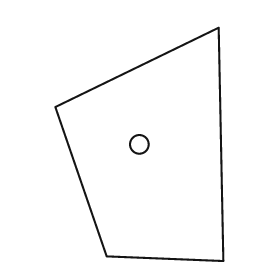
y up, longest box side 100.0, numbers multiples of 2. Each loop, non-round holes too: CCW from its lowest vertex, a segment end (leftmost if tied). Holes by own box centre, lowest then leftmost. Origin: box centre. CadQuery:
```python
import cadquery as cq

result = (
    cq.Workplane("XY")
    .moveTo(36.0, -50.0)
    .lineTo(34.0, 50.0)
    .lineTo(-36.0, 16.0)
    .lineTo(-14.0, -48.0)
    .close()
    .moveTo(0.0, 0.0)
    .circle(4.0)
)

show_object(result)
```